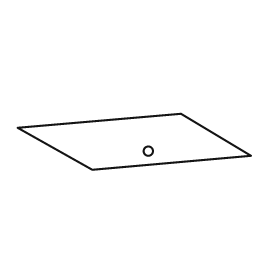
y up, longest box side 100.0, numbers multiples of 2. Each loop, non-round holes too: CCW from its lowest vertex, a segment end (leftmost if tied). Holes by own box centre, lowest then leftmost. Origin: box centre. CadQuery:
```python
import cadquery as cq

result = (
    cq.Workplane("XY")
    .moveTo(-18.0, -12.0)
    .lineTo(50.0, -6.0)
    .lineTo(20.0, 12.0)
    .lineTo(-50.0, 6.0)
    .close()
    .moveTo(6.0, -4.0)
    .circle(2.0)
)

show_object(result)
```